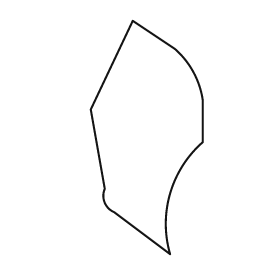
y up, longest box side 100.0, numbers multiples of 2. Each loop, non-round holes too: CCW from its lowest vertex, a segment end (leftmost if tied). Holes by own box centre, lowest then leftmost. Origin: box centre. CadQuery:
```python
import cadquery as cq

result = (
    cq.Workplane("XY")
    .moveTo(10.0, -50.0)
    .threePointArc((10.0, -24.0), (24.0, -2.0))
    .lineTo(24.0, 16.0)
    .threePointArc((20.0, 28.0), (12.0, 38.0))
    .lineTo(-6.0, 50.0)
    .lineTo(-24.0, 12.0)
    .lineTo(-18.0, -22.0)
    .threePointArc((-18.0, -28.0), (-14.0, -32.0))
    .close()
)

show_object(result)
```